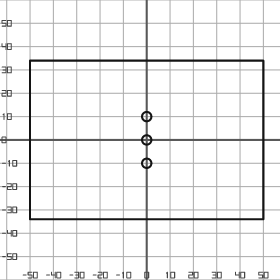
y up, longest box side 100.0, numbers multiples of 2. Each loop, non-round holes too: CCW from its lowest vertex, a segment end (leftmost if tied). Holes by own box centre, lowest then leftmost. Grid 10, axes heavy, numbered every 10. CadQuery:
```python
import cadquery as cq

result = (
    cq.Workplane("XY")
    .moveTo(-50.0, -34.0)
    .lineTo(50.0, -34.0)
    .lineTo(50.0, 34.0)
    .lineTo(-50.0, 34.0)
    .close()
    .moveTo(0.0, -10.0)
    .circle(2.0)
    .moveTo(0.0, 0.0)
    .circle(2.0)
    .moveTo(0.0, 10.0)
    .circle(2.0)
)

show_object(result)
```